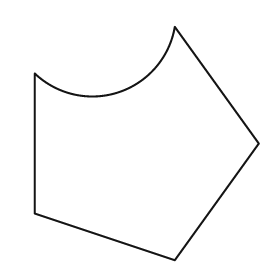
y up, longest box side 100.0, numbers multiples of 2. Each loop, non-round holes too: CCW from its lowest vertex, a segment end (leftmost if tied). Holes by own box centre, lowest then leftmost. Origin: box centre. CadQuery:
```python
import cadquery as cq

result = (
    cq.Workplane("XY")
    .moveTo(12.0, -50.0)
    .lineTo(48.0, 0.0)
    .lineTo(12.0, 50.0)
    .threePointArc((-12.0, 22.0), (-48.0, 30.0))
    .lineTo(-48.0, -30.0)
    .close()
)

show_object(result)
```